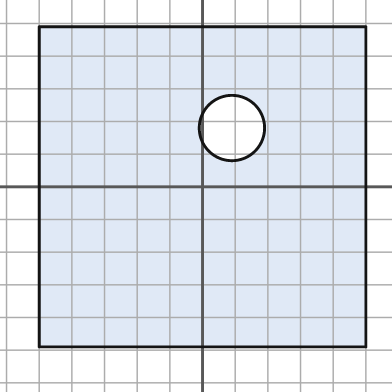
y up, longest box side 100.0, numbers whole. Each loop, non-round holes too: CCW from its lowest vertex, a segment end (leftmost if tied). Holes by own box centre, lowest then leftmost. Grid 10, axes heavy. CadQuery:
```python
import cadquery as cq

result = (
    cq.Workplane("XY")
    .moveTo(-50.0, -49.0)
    .lineTo(50.0, -49.0)
    .lineTo(50.0, 49.0)
    .lineTo(-50.0, 49.0)
    .close()
    .moveTo(9.0, 18.0)
    .circle(10.0)
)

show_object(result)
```